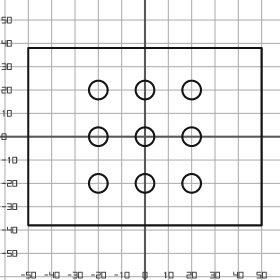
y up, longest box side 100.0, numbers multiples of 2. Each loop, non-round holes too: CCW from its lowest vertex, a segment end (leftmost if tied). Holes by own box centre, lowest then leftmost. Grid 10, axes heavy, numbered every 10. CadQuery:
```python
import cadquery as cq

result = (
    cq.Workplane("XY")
    .moveTo(-50.0, -38.0)
    .lineTo(50.0, -38.0)
    .lineTo(50.0, 38.0)
    .lineTo(-50.0, 38.0)
    .close()
    .moveTo(-20.0, -20.0)
    .circle(4.0)
    .moveTo(0.0, -20.0)
    .circle(4.0)
    .moveTo(20.0, -20.0)
    .circle(4.0)
    .moveTo(-20.0, 0.0)
    .circle(4.0)
    .moveTo(0.0, 0.0)
    .circle(4.0)
    .moveTo(20.0, 0.0)
    .circle(4.0)
    .moveTo(-20.0, 20.0)
    .circle(4.0)
    .moveTo(0.0, 20.0)
    .circle(4.0)
    .moveTo(20.0, 20.0)
    .circle(4.0)
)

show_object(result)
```